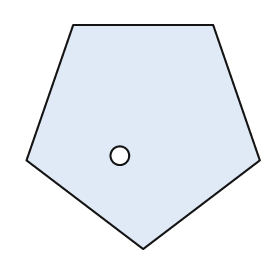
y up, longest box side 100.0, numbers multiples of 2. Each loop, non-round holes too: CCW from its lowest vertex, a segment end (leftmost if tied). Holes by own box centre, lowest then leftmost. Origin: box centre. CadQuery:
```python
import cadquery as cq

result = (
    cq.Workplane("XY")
    .moveTo(0.0, -48.0)
    .lineTo(50.0, -10.0)
    .lineTo(30.0, 48.0)
    .lineTo(-30.0, 48.0)
    .lineTo(-50.0, -10.0)
    .close()
    .moveTo(-10.0, -8.0)
    .circle(4.0)
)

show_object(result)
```